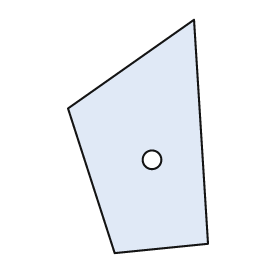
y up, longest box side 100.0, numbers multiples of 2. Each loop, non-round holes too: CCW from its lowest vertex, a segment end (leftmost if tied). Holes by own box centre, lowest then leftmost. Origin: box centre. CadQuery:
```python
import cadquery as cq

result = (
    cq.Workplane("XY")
    .moveTo(-10.0, -50.0)
    .lineTo(30.0, -46.0)
    .lineTo(24.0, 50.0)
    .lineTo(-30.0, 12.0)
    .close()
    .moveTo(6.0, -10.0)
    .circle(4.0)
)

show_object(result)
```